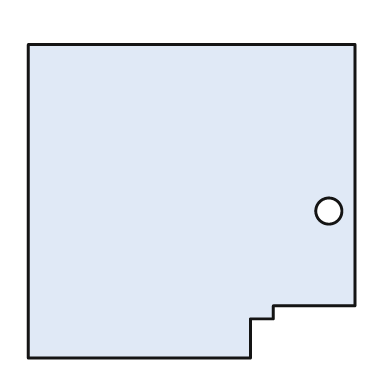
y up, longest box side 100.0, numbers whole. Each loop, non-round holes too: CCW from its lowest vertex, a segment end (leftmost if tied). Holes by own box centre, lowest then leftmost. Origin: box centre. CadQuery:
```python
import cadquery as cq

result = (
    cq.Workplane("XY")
    .moveTo(-50.0, -48.0)
    .lineTo(18.0, -48.0)
    .lineTo(18.0, -36.0)
    .lineTo(25.0, -36.0)
    .lineTo(25.0, -32.0)
    .lineTo(50.0, -32.0)
    .lineTo(50.0, 48.0)
    .lineTo(-50.0, 48.0)
    .close()
    .moveTo(42.0, -3.0)
    .circle(4.0)
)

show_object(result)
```